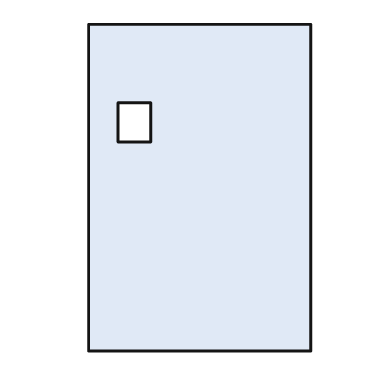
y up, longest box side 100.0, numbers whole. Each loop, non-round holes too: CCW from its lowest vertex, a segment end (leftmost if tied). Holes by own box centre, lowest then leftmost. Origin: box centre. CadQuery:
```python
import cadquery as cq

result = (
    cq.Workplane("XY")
    .moveTo(-34.0, -50.0)
    .lineTo(34.0, -50.0)
    .lineTo(34.0, 50.0)
    .lineTo(-34.0, 50.0)
    .close()
    .moveTo(-25.0, 14.0)
    .lineTo(-15.0, 14.0)
    .lineTo(-15.0, 26.0)
    .lineTo(-25.0, 26.0)
    .close()
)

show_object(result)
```